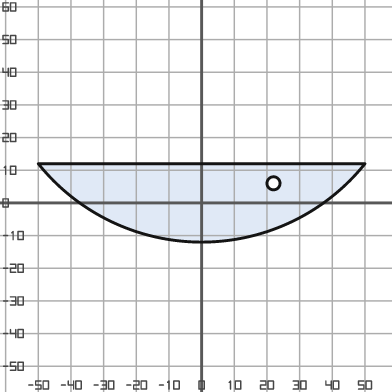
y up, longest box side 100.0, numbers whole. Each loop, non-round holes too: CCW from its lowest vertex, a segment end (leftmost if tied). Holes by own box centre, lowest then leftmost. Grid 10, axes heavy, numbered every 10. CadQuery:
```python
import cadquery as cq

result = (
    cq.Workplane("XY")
    .moveTo(-50.0, 12.0)
    .threePointArc((0.0, -12.0), (50.0, 12.0))
    .close()
    .moveTo(22.0, 6.0)
    .circle(2.0)
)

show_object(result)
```